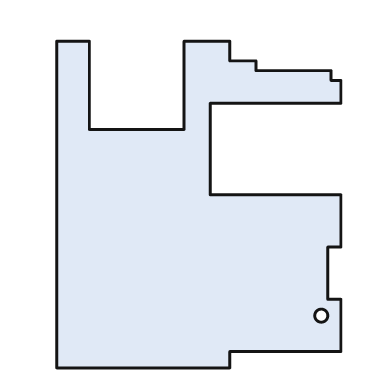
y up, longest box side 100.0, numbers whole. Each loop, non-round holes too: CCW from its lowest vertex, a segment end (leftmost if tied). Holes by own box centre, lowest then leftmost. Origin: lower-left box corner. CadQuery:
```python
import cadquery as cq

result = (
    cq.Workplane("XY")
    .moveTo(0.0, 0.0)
    .lineTo(53.0, 0.0)
    .lineTo(53.0, 5.0)
    .lineTo(87.0, 5.0)
    .lineTo(87.0, 21.0)
    .lineTo(83.0, 21.0)
    .lineTo(83.0, 37.0)
    .lineTo(87.0, 37.0)
    .lineTo(87.0, 53.0)
    .lineTo(47.0, 53.0)
    .lineTo(47.0, 81.0)
    .lineTo(87.0, 81.0)
    .lineTo(87.0, 88.0)
    .lineTo(84.0, 88.0)
    .lineTo(84.0, 91.0)
    .lineTo(61.0, 91.0)
    .lineTo(61.0, 94.0)
    .lineTo(53.0, 94.0)
    .lineTo(53.0, 100.0)
    .lineTo(39.0, 100.0)
    .lineTo(39.0, 73.0)
    .lineTo(10.0, 73.0)
    .lineTo(10.0, 100.0)
    .lineTo(0.0, 100.0)
    .close()
    .moveTo(81.0, 16.0)
    .circle(2.0)
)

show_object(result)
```